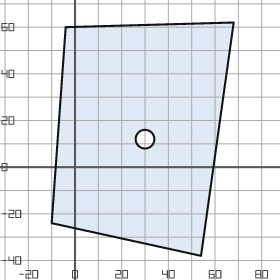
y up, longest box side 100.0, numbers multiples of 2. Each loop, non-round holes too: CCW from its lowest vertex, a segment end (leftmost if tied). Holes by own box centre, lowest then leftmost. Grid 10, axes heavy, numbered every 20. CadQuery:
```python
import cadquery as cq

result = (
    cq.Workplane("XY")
    .moveTo(54.0, -38.0)
    .lineTo(68.0, 62.0)
    .lineTo(-4.0, 60.0)
    .lineTo(-10.0, -24.0)
    .close()
    .moveTo(30.0, 12.0)
    .circle(4.0)
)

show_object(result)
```